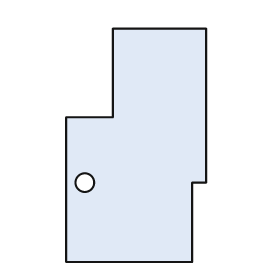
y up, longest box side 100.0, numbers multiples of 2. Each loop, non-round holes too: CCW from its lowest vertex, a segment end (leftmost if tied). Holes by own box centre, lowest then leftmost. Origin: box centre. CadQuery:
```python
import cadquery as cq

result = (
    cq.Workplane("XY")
    .moveTo(-30.0, -50.0)
    .lineTo(24.0, -50.0)
    .lineTo(24.0, -16.0)
    .lineTo(30.0, -16.0)
    .lineTo(30.0, 50.0)
    .lineTo(-10.0, 50.0)
    .lineTo(-10.0, 12.0)
    .lineTo(-30.0, 12.0)
    .close()
    .moveTo(-22.0, -16.0)
    .circle(4.0)
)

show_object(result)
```